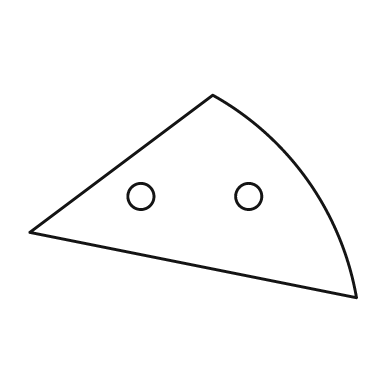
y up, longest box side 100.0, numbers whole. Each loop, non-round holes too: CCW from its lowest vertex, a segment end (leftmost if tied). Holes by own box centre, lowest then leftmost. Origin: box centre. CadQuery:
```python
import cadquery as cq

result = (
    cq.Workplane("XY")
    .moveTo(50.0, -31.0)
    .threePointArc((35.0, 5.0), (6.0, 31.0))
    .lineTo(-50.0, -11.0)
    .close()
    .moveTo(-16.0, 0.0)
    .circle(4.0)
    .moveTo(17.0, 0.0)
    .circle(4.0)
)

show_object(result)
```